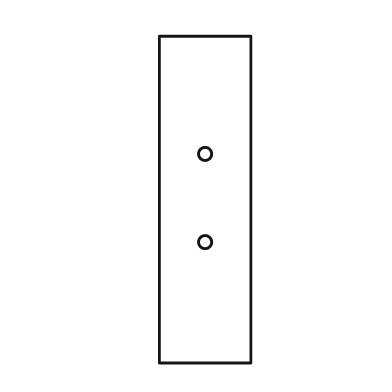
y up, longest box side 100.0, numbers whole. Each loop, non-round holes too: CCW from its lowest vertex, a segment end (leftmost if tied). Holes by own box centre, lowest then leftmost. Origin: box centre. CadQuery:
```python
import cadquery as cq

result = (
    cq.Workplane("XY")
    .moveTo(-14.0, -50.0)
    .lineTo(14.0, -50.0)
    .lineTo(14.0, 50.0)
    .lineTo(-14.0, 50.0)
    .close()
    .moveTo(0.0, -13.0)
    .circle(2.0)
    .moveTo(0.0, 14.0)
    .circle(2.0)
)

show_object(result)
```